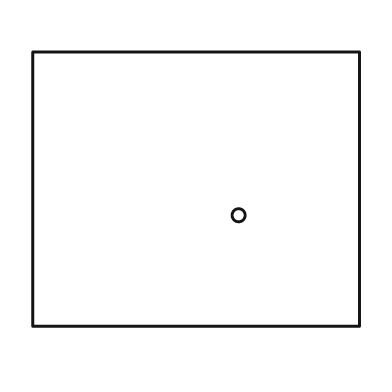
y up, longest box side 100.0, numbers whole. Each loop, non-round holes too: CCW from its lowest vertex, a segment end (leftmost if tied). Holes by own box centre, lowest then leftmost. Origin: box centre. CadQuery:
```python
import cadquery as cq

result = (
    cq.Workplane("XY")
    .moveTo(-50.0, -42.0)
    .lineTo(50.0, -42.0)
    .lineTo(50.0, 42.0)
    .lineTo(-50.0, 42.0)
    .close()
    .moveTo(13.0, -8.0)
    .circle(2.0)
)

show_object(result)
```